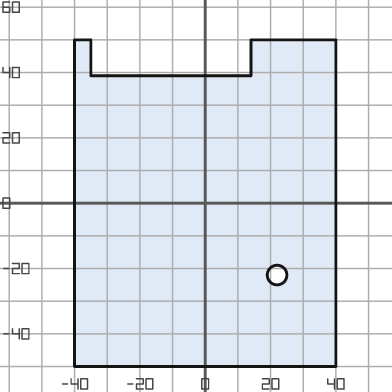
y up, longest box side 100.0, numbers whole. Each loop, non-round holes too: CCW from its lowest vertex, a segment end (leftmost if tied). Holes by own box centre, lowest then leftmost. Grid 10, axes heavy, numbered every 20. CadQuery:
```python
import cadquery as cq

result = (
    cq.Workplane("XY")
    .moveTo(-40.0, -50.0)
    .lineTo(40.0, -50.0)
    .lineTo(40.0, 50.0)
    .lineTo(14.0, 50.0)
    .lineTo(14.0, 39.0)
    .lineTo(-35.0, 39.0)
    .lineTo(-35.0, 50.0)
    .lineTo(-40.0, 50.0)
    .close()
    .moveTo(22.0, -22.0)
    .circle(3.0)
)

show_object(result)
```